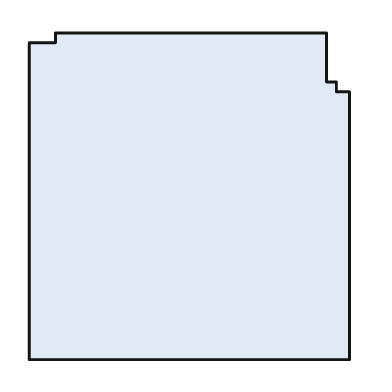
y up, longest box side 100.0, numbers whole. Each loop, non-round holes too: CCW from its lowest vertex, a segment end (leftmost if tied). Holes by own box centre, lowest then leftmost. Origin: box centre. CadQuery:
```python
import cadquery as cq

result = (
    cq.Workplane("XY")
    .moveTo(-49.0, -50.0)
    .lineTo(49.0, -50.0)
    .lineTo(49.0, 32.0)
    .lineTo(45.0, 32.0)
    .lineTo(45.0, 35.0)
    .lineTo(42.0, 35.0)
    .lineTo(42.0, 50.0)
    .lineTo(-41.0, 50.0)
    .lineTo(-41.0, 47.0)
    .lineTo(-49.0, 47.0)
    .close()
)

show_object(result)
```